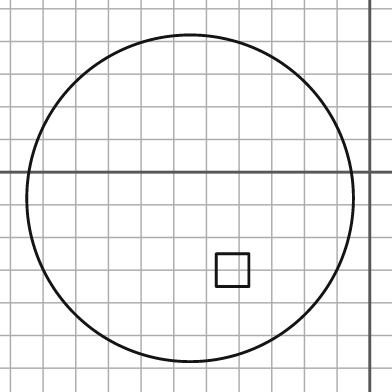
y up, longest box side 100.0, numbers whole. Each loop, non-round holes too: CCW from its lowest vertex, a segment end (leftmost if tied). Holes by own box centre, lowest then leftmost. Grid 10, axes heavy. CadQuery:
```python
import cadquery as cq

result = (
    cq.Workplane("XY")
    .moveTo(-55.0, -8.0)
    .circle(50.0)
    .moveTo(-47.0, -35.0)
    .lineTo(-37.0, -35.0)
    .lineTo(-37.0, -25.0)
    .lineTo(-47.0, -25.0)
    .close()
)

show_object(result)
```